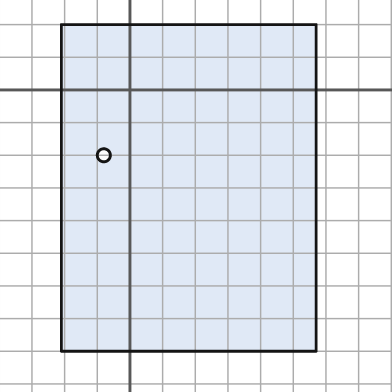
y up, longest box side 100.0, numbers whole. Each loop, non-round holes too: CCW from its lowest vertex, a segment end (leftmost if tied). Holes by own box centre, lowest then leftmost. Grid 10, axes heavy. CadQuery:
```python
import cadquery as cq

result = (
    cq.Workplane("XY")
    .moveTo(-21.0, -80.0)
    .lineTo(57.0, -80.0)
    .lineTo(57.0, 20.0)
    .lineTo(-21.0, 20.0)
    .close()
    .moveTo(-8.0, -20.0)
    .circle(2.0)
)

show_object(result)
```